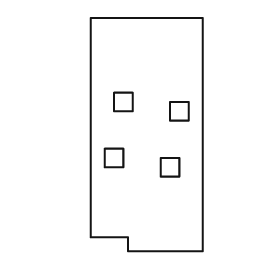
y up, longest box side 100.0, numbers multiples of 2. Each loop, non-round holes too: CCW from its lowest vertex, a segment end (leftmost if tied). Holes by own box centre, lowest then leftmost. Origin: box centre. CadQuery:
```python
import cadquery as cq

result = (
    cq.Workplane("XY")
    .moveTo(-8.0, -50.0)
    .lineTo(24.0, -50.0)
    .lineTo(24.0, 50.0)
    .lineTo(-24.0, 50.0)
    .lineTo(-24.0, -44.0)
    .lineTo(-8.0, -44.0)
    .close()
    .moveTo(6.0, -18.0)
    .lineTo(14.0, -18.0)
    .lineTo(14.0, -10.0)
    .lineTo(6.0, -10.0)
    .close()
    .moveTo(-18.0, -14.0)
    .lineTo(-10.0, -14.0)
    .lineTo(-10.0, -6.0)
    .lineTo(-18.0, -6.0)
    .close()
    .moveTo(10.0, 6.0)
    .lineTo(18.0, 6.0)
    .lineTo(18.0, 14.0)
    .lineTo(10.0, 14.0)
    .close()
    .moveTo(-14.0, 10.0)
    .lineTo(-6.0, 10.0)
    .lineTo(-6.0, 18.0)
    .lineTo(-14.0, 18.0)
    .close()
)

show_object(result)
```